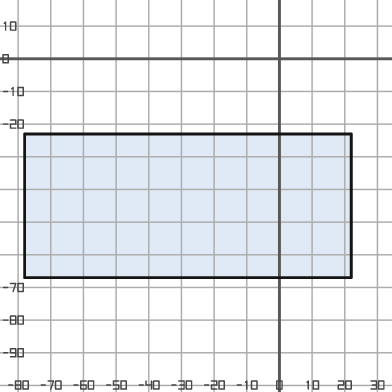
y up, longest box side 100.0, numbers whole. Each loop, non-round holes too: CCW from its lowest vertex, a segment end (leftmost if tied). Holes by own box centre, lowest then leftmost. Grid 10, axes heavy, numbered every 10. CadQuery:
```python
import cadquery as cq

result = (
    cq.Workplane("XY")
    .moveTo(-78.0, -67.0)
    .lineTo(22.0, -67.0)
    .lineTo(22.0, -23.0)
    .lineTo(-78.0, -23.0)
    .close()
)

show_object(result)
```